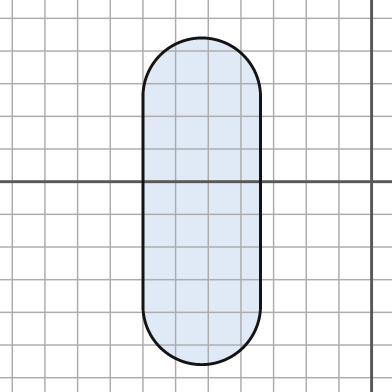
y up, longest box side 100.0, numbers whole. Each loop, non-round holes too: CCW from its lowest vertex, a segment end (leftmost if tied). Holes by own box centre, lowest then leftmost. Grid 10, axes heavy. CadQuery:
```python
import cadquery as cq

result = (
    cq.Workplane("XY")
    .moveTo(-70.0, -38.0)
    .threePointArc((-52.0, -56.0), (-34.0, -38.0))
    .lineTo(-34.0, 26.0)
    .threePointArc((-52.0, 44.0), (-70.0, 26.0))
    .close()
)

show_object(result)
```